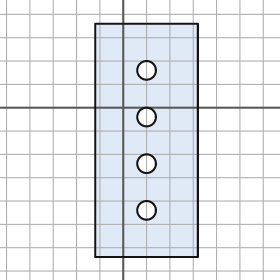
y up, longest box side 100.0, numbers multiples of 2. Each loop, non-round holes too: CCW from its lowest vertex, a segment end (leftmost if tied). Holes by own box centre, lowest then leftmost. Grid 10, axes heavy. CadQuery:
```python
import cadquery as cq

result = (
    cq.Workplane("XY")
    .moveTo(-12.0, -64.0)
    .lineTo(32.0, -64.0)
    .lineTo(32.0, 36.0)
    .lineTo(-12.0, 36.0)
    .close()
    .moveTo(10.0, -44.0)
    .circle(4.0)
    .moveTo(10.0, -24.0)
    .circle(4.0)
    .moveTo(10.0, -4.0)
    .circle(4.0)
    .moveTo(10.0, 16.0)
    .circle(4.0)
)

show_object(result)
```